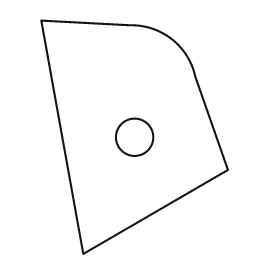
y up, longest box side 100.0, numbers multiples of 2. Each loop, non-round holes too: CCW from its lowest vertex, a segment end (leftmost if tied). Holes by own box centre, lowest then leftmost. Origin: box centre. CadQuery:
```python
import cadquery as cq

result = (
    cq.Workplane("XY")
    .moveTo(-22.0, -50.0)
    .lineTo(40.0, -14.0)
    .lineTo(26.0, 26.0)
    .threePointArc((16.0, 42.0), (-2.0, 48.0))
    .lineTo(-40.0, 50.0)
    .close()
    .moveTo(0.0, 0.0)
    .circle(8.0)
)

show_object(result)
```